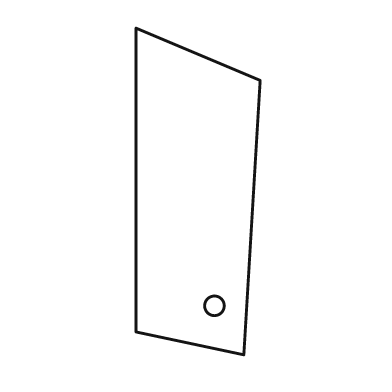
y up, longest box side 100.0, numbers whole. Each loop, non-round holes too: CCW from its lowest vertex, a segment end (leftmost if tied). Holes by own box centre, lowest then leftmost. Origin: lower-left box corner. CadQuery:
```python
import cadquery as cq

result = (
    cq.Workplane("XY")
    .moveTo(33.0, 0.0)
    .lineTo(38.0, 84.0)
    .lineTo(0.0, 100.0)
    .lineTo(0.0, 7.0)
    .close()
    .moveTo(24.0, 15.0)
    .circle(3.0)
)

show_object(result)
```